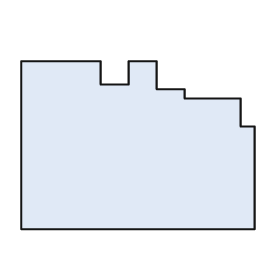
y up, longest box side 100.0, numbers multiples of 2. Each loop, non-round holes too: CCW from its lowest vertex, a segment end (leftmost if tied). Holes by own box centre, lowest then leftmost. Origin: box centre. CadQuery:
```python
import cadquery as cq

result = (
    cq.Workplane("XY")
    .moveTo(-50.0, -36.0)
    .lineTo(50.0, -36.0)
    .lineTo(50.0, 8.0)
    .lineTo(44.0, 8.0)
    .lineTo(44.0, 20.0)
    .lineTo(20.0, 20.0)
    .lineTo(20.0, 24.0)
    .lineTo(8.0, 24.0)
    .lineTo(8.0, 36.0)
    .lineTo(-4.0, 36.0)
    .lineTo(-4.0, 26.0)
    .lineTo(-16.0, 26.0)
    .lineTo(-16.0, 36.0)
    .lineTo(-50.0, 36.0)
    .close()
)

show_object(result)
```